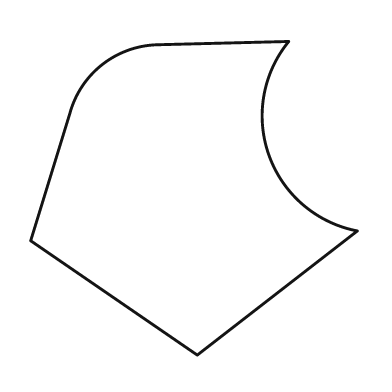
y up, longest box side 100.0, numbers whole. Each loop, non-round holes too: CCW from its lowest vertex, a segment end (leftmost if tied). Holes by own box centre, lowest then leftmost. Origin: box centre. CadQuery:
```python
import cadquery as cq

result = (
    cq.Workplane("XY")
    .moveTo(1.0, -48.0)
    .lineTo(50.0, -10.0)
    .threePointArc((23.0, 13.0), (29.0, 48.0))
    .lineTo(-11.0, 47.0)
    .threePointArc((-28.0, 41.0), (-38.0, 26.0))
    .lineTo(-50.0, -13.0)
    .close()
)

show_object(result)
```